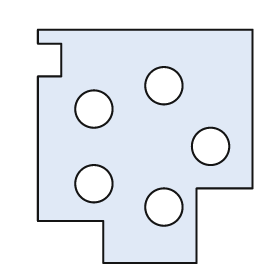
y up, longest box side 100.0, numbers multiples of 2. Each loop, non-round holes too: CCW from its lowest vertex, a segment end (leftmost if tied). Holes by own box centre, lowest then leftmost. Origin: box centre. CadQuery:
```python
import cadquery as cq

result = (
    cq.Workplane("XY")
    .moveTo(-18.0, -50.0)
    .lineTo(22.0, -50.0)
    .lineTo(22.0, -18.0)
    .lineTo(46.0, -18.0)
    .lineTo(46.0, 50.0)
    .lineTo(-46.0, 50.0)
    .lineTo(-46.0, 44.0)
    .lineTo(-36.0, 44.0)
    .lineTo(-36.0, 30.0)
    .lineTo(-46.0, 30.0)
    .lineTo(-46.0, -32.0)
    .lineTo(-18.0, -32.0)
    .close()
    .moveTo(8.0, -26.0)
    .circle(8.0)
    .moveTo(-22.0, -16.0)
    .circle(8.0)
    .moveTo(28.0, 0.0)
    .circle(8.0)
    .moveTo(-22.0, 16.0)
    .circle(8.0)
    .moveTo(8.0, 26.0)
    .circle(8.0)
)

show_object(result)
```